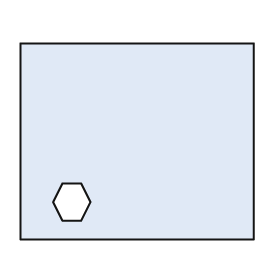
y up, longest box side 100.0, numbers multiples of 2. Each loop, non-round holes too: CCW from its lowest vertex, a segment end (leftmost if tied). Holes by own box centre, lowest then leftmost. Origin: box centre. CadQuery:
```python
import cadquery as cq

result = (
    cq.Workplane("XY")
    .moveTo(-50.0, -42.0)
    .lineTo(50.0, -42.0)
    .lineTo(50.0, 42.0)
    .lineTo(-50.0, 42.0)
    .close()
    .moveTo(-32.0, -34.0)
    .lineTo(-24.0, -34.0)
    .lineTo(-20.0, -26.0)
    .lineTo(-24.0, -18.0)
    .lineTo(-32.0, -18.0)
    .lineTo(-36.0, -26.0)
    .close()
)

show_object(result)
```